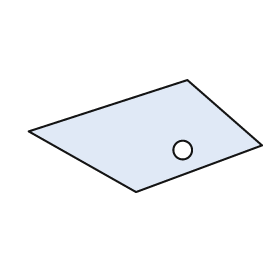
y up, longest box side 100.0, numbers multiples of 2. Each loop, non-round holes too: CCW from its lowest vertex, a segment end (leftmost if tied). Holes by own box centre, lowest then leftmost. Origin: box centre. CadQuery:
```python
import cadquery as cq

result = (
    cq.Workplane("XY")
    .moveTo(-4.0, -24.0)
    .lineTo(50.0, -4.0)
    .lineTo(18.0, 24.0)
    .lineTo(-50.0, 2.0)
    .close()
    .moveTo(16.0, -6.0)
    .circle(4.0)
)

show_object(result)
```